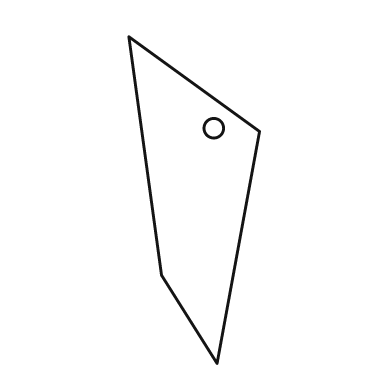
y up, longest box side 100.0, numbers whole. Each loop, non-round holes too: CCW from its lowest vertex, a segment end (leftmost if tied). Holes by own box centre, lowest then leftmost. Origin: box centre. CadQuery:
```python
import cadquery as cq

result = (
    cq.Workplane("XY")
    .moveTo(7.0, -50.0)
    .lineTo(20.0, 21.0)
    .lineTo(-20.0, 50.0)
    .lineTo(-10.0, -23.0)
    .close()
    .moveTo(6.0, 22.0)
    .circle(3.0)
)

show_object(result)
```